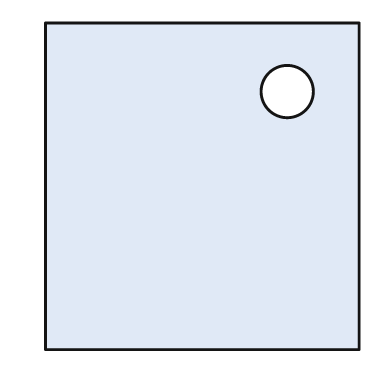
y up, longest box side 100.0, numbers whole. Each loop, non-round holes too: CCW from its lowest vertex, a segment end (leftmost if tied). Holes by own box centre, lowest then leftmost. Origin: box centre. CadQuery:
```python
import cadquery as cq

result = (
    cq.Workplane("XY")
    .moveTo(-48.0, -50.0)
    .lineTo(48.0, -50.0)
    .lineTo(48.0, 50.0)
    .lineTo(-48.0, 50.0)
    .close()
    .moveTo(26.0, 29.0)
    .circle(8.0)
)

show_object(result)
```